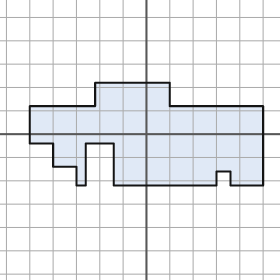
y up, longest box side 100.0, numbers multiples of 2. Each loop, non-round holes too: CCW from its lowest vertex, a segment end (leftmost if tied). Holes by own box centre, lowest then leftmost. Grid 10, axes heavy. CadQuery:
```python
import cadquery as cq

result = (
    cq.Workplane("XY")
    .moveTo(-30.0, -22.0)
    .lineTo(-26.0, -22.0)
    .lineTo(-26.0, -4.0)
    .lineTo(-14.0, -4.0)
    .lineTo(-14.0, -22.0)
    .lineTo(30.0, -22.0)
    .lineTo(30.0, -16.0)
    .lineTo(36.0, -16.0)
    .lineTo(36.0, -22.0)
    .lineTo(50.0, -22.0)
    .lineTo(50.0, 12.0)
    .lineTo(10.0, 12.0)
    .lineTo(10.0, 22.0)
    .lineTo(-22.0, 22.0)
    .lineTo(-22.0, 12.0)
    .lineTo(-50.0, 12.0)
    .lineTo(-50.0, -4.0)
    .lineTo(-40.0, -4.0)
    .lineTo(-40.0, -14.0)
    .lineTo(-30.0, -14.0)
    .close()
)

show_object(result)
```